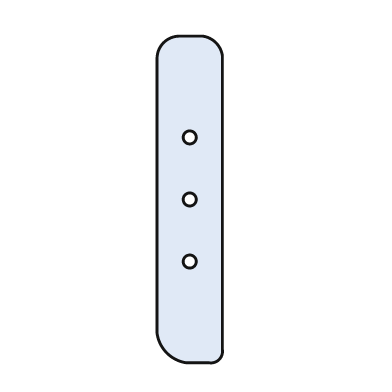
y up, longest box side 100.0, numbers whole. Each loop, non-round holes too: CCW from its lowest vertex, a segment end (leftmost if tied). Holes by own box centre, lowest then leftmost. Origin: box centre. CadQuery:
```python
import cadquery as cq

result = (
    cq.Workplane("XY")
    .moveTo(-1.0, -50.0)
    .lineTo(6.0, -50.0)
    .threePointArc((9.0, -49.0), (10.0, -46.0))
    .lineTo(10.0, 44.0)
    .threePointArc((8.0, 48.0), (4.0, 50.0))
    .lineTo(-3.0, 50.0)
    .threePointArc((-8.0, 48.0), (-10.0, 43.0))
    .lineTo(-10.0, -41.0)
    .threePointArc((-7.0, -47.0), (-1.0, -50.0))
    .close()
    .moveTo(0.0, -19.0)
    .circle(2.0)
    .moveTo(0.0, 0.0)
    .circle(2.0)
    .moveTo(0.0, 19.0)
    .circle(2.0)
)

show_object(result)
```